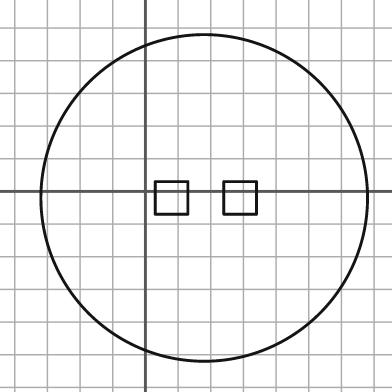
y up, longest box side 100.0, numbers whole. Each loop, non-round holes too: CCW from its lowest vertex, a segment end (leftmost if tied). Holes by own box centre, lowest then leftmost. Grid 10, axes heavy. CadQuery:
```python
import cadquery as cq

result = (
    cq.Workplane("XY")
    .moveTo(18.0, -2.0)
    .circle(50.0)
    .moveTo(3.0, -7.0)
    .lineTo(13.0, -7.0)
    .lineTo(13.0, 3.0)
    .lineTo(3.0, 3.0)
    .close()
    .moveTo(24.0, -7.0)
    .lineTo(34.0, -7.0)
    .lineTo(34.0, 3.0)
    .lineTo(24.0, 3.0)
    .close()
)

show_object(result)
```